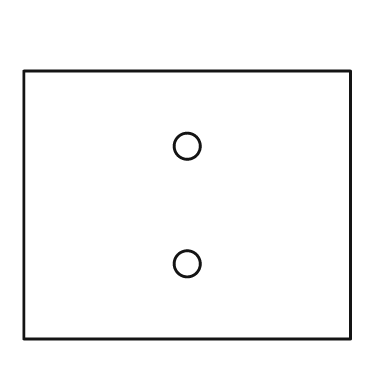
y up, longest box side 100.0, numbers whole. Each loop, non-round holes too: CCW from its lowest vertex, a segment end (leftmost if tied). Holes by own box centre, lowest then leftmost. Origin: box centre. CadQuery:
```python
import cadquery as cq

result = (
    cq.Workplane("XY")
    .moveTo(-50.0, -41.0)
    .lineTo(50.0, -41.0)
    .lineTo(50.0, 41.0)
    .lineTo(-50.0, 41.0)
    .close()
    .moveTo(0.0, -18.0)
    .circle(4.0)
    .moveTo(0.0, 18.0)
    .circle(4.0)
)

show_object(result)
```